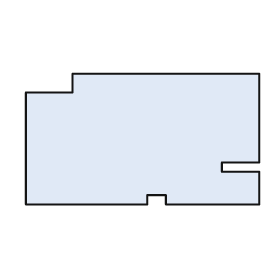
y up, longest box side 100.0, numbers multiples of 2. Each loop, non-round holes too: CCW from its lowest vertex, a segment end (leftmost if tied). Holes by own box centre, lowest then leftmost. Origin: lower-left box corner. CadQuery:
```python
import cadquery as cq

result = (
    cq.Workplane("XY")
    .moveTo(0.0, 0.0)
    .lineTo(52.0, 0.0)
    .lineTo(52.0, 4.0)
    .lineTo(60.0, 4.0)
    .lineTo(60.0, 0.0)
    .lineTo(100.0, 0.0)
    .lineTo(100.0, 14.0)
    .lineTo(84.0, 14.0)
    .lineTo(84.0, 18.0)
    .lineTo(100.0, 18.0)
    .lineTo(100.0, 56.0)
    .lineTo(20.0, 56.0)
    .lineTo(20.0, 48.0)
    .lineTo(0.0, 48.0)
    .close()
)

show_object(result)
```